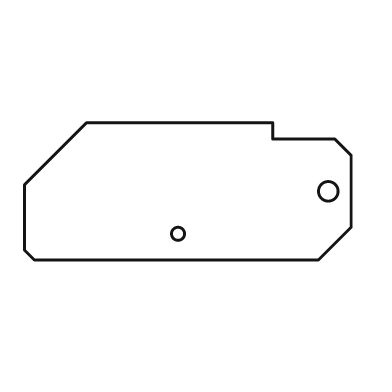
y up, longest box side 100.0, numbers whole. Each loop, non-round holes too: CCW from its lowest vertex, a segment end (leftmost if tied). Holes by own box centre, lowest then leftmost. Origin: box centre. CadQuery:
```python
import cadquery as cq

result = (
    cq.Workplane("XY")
    .moveTo(-47.0, -21.0)
    .lineTo(40.0, -21.0)
    .lineTo(50.0, -11.0)
    .lineTo(50.0, 11.0)
    .lineTo(45.0, 16.0)
    .lineTo(26.0, 16.0)
    .lineTo(26.0, 21.0)
    .lineTo(-31.0, 21.0)
    .lineTo(-50.0, 2.0)
    .lineTo(-50.0, -18.0)
    .close()
    .moveTo(-3.0, -13.0)
    .circle(2.0)
    .moveTo(43.0, 0.0)
    .circle(3.0)
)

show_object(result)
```